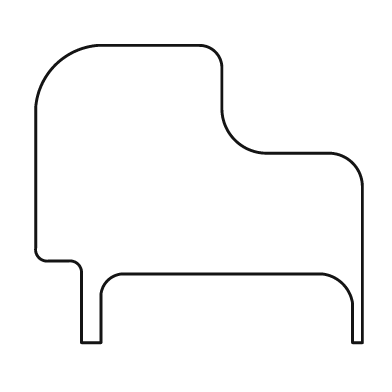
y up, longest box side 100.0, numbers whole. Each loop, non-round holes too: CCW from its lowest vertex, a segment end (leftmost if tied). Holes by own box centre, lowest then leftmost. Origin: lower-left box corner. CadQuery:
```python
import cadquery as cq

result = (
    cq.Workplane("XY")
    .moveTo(14.0, 0.0)
    .lineTo(20.0, 0.0)
    .lineTo(20.0, 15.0)
    .threePointArc((22.0, 19.0), (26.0, 21.0))
    .lineTo(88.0, 21.0)
    .threePointArc((94.0, 18.0), (97.0, 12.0))
    .lineTo(97.0, 0.0)
    .lineTo(100.0, 0.0)
    .lineTo(100.0, 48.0)
    .threePointArc((97.0, 55.0), (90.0, 58.0))
    .lineTo(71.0, 58.0)
    .threePointArc((61.0, 62.0), (57.0, 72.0))
    .lineTo(57.0, 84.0)
    .threePointArc((55.0, 89.0), (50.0, 91.0))
    .lineTo(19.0, 91.0)
    .threePointArc((6.0, 85.0), (0.0, 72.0))
    .lineTo(0.0, 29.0)
    .threePointArc((1.0, 26.0), (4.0, 25.0))
    .lineTo(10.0, 25.0)
    .threePointArc((13.0, 24.0), (14.0, 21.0))
    .close()
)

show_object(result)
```